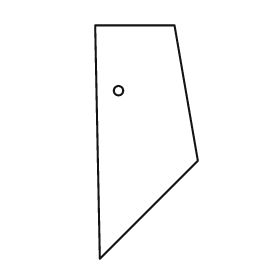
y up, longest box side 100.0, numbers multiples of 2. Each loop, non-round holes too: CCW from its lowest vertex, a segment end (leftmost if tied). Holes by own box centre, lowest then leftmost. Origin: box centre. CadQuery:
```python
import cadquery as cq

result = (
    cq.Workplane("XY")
    .moveTo(-20.0, -50.0)
    .lineTo(22.0, -8.0)
    .lineTo(12.0, 50.0)
    .lineTo(-22.0, 50.0)
    .close()
    .moveTo(-12.0, 22.0)
    .circle(2.0)
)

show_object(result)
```